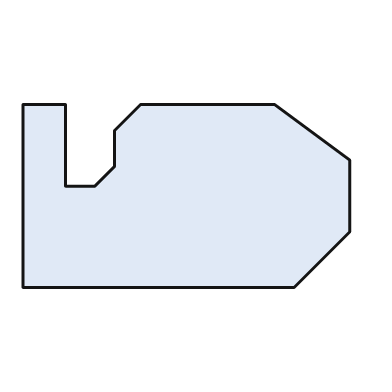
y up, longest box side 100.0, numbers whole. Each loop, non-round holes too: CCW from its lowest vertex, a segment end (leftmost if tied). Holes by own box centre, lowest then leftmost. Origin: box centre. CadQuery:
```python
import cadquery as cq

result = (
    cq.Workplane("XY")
    .moveTo(-50.0, -28.0)
    .lineTo(33.0, -28.0)
    .lineTo(50.0, -11.0)
    .lineTo(50.0, 11.0)
    .lineTo(27.0, 28.0)
    .lineTo(-14.0, 28.0)
    .lineTo(-22.0, 20.0)
    .lineTo(-22.0, 9.0)
    .lineTo(-28.0, 3.0)
    .lineTo(-37.0, 3.0)
    .lineTo(-37.0, 28.0)
    .lineTo(-50.0, 28.0)
    .close()
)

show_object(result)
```